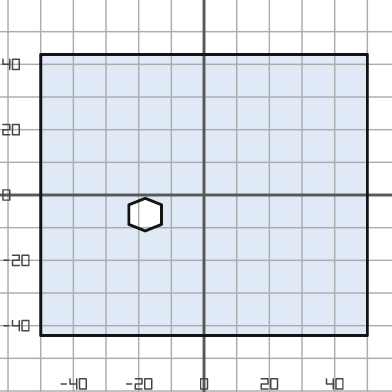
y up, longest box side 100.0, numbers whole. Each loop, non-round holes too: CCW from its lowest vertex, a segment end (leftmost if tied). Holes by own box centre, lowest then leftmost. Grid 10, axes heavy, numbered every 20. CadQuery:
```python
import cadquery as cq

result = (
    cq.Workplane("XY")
    .moveTo(-50.0, -43.0)
    .lineTo(50.0, -43.0)
    .lineTo(50.0, 43.0)
    .lineTo(-50.0, 43.0)
    .close()
    .moveTo(-18.0, -11.0)
    .lineTo(-13.0, -9.0)
    .lineTo(-13.0, -3.0)
    .lineTo(-18.0, -1.0)
    .lineTo(-23.0, -3.0)
    .lineTo(-23.0, -9.0)
    .close()
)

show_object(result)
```